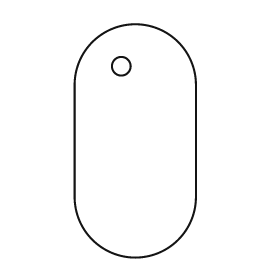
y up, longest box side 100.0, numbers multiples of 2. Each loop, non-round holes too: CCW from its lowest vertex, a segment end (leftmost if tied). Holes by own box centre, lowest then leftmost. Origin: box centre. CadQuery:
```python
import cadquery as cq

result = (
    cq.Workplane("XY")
    .moveTo(-26.0, -24.0)
    .threePointArc((0.0, -50.0), (26.0, -24.0))
    .lineTo(26.0, 24.0)
    .threePointArc((0.0, 50.0), (-26.0, 24.0))
    .close()
    .moveTo(-6.0, 32.0)
    .circle(4.0)
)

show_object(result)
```